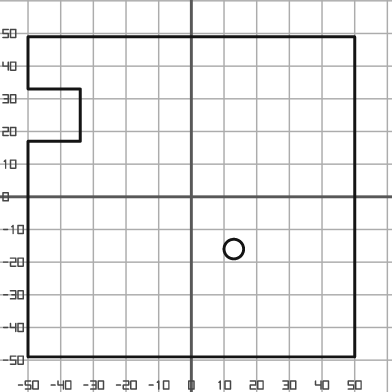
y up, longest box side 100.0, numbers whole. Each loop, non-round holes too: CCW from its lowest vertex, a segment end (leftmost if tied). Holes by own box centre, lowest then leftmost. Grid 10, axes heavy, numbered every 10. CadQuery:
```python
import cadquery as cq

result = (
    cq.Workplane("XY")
    .moveTo(-50.0, -49.0)
    .lineTo(50.0, -49.0)
    .lineTo(50.0, 49.0)
    .lineTo(-50.0, 49.0)
    .lineTo(-50.0, 33.0)
    .lineTo(-34.0, 33.0)
    .lineTo(-34.0, 17.0)
    .lineTo(-50.0, 17.0)
    .close()
    .moveTo(13.0, -16.0)
    .circle(3.0)
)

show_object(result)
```